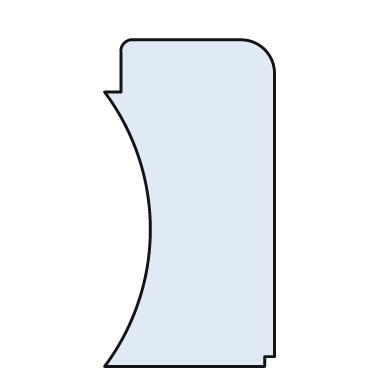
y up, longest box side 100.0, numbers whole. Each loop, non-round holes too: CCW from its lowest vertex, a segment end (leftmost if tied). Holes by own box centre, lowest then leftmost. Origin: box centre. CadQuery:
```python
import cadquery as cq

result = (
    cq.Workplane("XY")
    .moveTo(-26.0, -50.0)
    .lineTo(23.0, -50.0)
    .lineTo(23.0, -47.0)
    .lineTo(26.0, -47.0)
    .lineTo(26.0, 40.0)
    .threePointArc((23.0, 47.0), (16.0, 50.0))
    .lineTo(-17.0, 50.0)
    .threePointArc((-20.0, 49.0), (-21.0, 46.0))
    .lineTo(-21.0, 34.0)
    .lineTo(-26.0, 34.0)
    .threePointArc((-12.0, -8.0), (-26.0, -50.0))
    .close()
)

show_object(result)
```